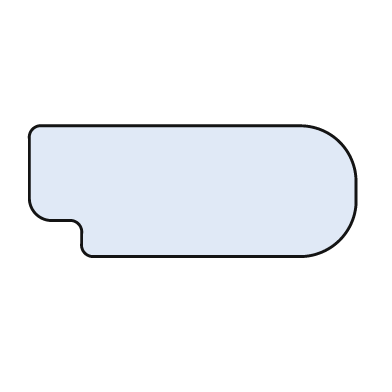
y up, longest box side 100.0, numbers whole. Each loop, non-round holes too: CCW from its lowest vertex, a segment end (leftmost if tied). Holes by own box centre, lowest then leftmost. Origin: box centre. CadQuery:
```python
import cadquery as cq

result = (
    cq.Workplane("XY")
    .moveTo(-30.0, -20.0)
    .lineTo(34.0, -20.0)
    .threePointArc((45.0, -15.0), (50.0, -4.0))
    .lineTo(50.0, 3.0)
    .threePointArc((45.0, 15.0), (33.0, 20.0))
    .lineTo(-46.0, 20.0)
    .threePointArc((-49.0, 19.0), (-50.0, 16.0))
    .lineTo(-50.0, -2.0)
    .threePointArc((-48.0, -7.0), (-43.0, -9.0))
    .lineTo(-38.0, -9.0)
    .threePointArc((-35.0, -10.0), (-34.0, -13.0))
    .lineTo(-34.0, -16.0)
    .threePointArc((-33.0, -19.0), (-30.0, -20.0))
    .close()
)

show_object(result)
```